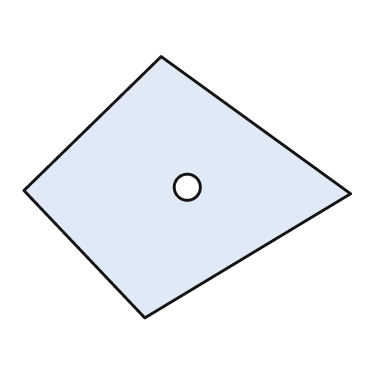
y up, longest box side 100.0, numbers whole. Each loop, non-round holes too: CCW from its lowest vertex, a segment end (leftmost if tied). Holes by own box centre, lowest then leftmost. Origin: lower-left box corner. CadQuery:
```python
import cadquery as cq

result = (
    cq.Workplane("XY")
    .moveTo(37.0, 0.0)
    .lineTo(100.0, 38.0)
    .lineTo(42.0, 80.0)
    .lineTo(0.0, 39.0)
    .close()
    .moveTo(50.0, 40.0)
    .circle(4.0)
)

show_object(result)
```